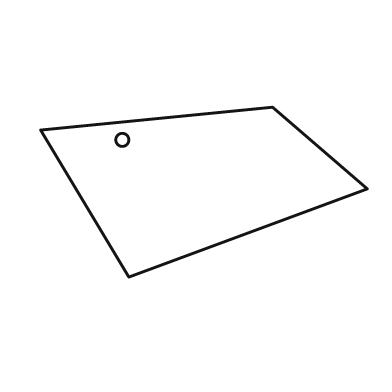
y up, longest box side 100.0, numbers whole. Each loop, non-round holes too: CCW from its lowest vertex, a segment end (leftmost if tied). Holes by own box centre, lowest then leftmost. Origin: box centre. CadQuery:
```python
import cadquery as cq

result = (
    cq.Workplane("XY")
    .moveTo(-23.0, -26.0)
    .lineTo(50.0, 1.0)
    .lineTo(21.0, 26.0)
    .lineTo(-50.0, 19.0)
    .close()
    .moveTo(-25.0, 16.0)
    .circle(2.0)
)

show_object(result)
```